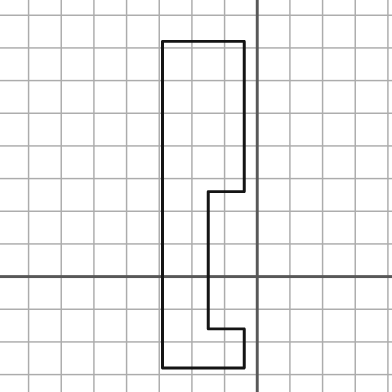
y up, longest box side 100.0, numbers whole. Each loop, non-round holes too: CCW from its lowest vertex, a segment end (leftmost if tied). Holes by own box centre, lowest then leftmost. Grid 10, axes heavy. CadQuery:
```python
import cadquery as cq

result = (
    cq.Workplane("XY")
    .moveTo(-29.0, -28.0)
    .lineTo(-4.0, -28.0)
    .lineTo(-4.0, -16.0)
    .lineTo(-15.0, -16.0)
    .lineTo(-15.0, 26.0)
    .lineTo(-4.0, 26.0)
    .lineTo(-4.0, 72.0)
    .lineTo(-29.0, 72.0)
    .close()
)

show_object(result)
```